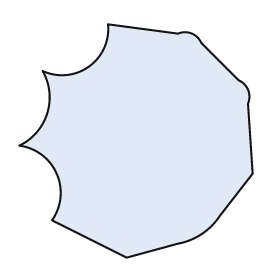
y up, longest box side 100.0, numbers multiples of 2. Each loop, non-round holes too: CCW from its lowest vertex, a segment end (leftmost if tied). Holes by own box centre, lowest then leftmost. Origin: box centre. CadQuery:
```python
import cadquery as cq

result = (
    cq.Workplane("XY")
    .moveTo(-4.0, -50.0)
    .lineTo(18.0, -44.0)
    .threePointArc((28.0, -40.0), (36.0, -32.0))
    .lineTo(50.0, -14.0)
    .lineTo(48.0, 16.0)
    .threePointArc((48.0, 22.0), (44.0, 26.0))
    .lineTo(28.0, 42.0)
    .threePointArc((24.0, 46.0), (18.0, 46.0))
    .lineTo(-12.0, 50.0)
    .threePointArc((-20.0, 32.0), (-40.0, 30.0))
    .threePointArc((-38.0, 12.0), (-50.0, -2.0))
    .threePointArc((-34.0, -14.0), (-36.0, -34.0))
    .close()
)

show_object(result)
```